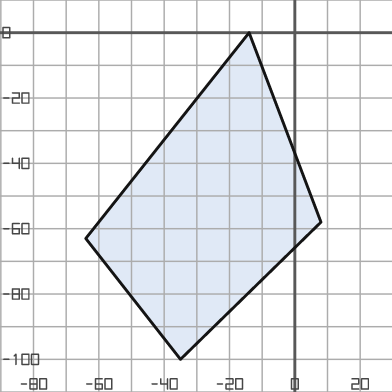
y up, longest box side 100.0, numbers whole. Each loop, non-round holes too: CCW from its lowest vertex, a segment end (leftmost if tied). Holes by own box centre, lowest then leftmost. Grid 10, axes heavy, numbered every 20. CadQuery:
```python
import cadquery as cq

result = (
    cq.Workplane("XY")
    .moveTo(-35.0, -100.0)
    .lineTo(8.0, -58.0)
    .lineTo(-14.0, 0.0)
    .lineTo(-64.0, -63.0)
    .close()
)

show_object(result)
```